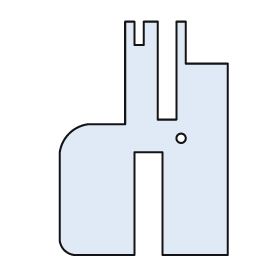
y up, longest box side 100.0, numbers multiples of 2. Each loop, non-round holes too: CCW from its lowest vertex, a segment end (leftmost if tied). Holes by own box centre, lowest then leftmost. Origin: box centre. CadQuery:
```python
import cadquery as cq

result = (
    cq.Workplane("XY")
    .moveTo(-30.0, -50.0)
    .lineTo(-4.0, -50.0)
    .lineTo(-4.0, -6.0)
    .lineTo(8.0, -6.0)
    .lineTo(8.0, -50.0)
    .lineTo(36.0, -50.0)
    .lineTo(36.0, 32.0)
    .lineTo(18.0, 32.0)
    .lineTo(18.0, 50.0)
    .lineTo(14.0, 50.0)
    .lineTo(14.0, 8.0)
    .lineTo(6.0, 8.0)
    .lineTo(6.0, 50.0)
    .lineTo(0.0, 50.0)
    .lineTo(0.0, 40.0)
    .lineTo(-4.0, 40.0)
    .lineTo(-4.0, 50.0)
    .lineTo(-8.0, 50.0)
    .lineTo(-8.0, 6.0)
    .lineTo(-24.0, 6.0)
    .threePointArc((-32.0, 2.0), (-36.0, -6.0))
    .lineTo(-36.0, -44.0)
    .threePointArc((-34.0, -48.0), (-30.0, -50.0))
    .close()
    .moveTo(16.0, 0.0)
    .circle(2.0)
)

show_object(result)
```